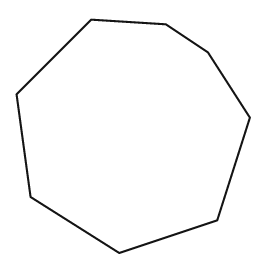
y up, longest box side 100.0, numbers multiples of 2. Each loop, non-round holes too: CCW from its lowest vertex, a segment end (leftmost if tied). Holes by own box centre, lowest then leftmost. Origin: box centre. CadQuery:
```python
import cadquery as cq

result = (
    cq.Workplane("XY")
    .moveTo(-6.0, -50.0)
    .lineTo(36.0, -36.0)
    .lineTo(50.0, 8.0)
    .lineTo(32.0, 36.0)
    .lineTo(14.0, 48.0)
    .lineTo(-18.0, 50.0)
    .lineTo(-50.0, 18.0)
    .lineTo(-44.0, -26.0)
    .close()
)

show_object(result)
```